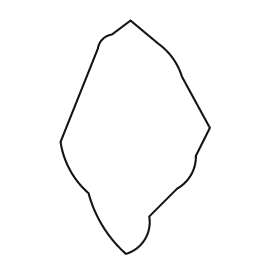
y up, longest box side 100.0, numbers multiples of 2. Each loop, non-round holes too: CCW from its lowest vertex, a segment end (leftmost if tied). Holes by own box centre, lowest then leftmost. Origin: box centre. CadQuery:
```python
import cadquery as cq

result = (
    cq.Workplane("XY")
    .moveTo(-4.0, -50.0)
    .threePointArc((4.0, -44.0), (6.0, -34.0))
    .lineTo(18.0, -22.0)
    .threePointArc((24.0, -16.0), (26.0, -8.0))
    .lineTo(32.0, 4.0)
    .lineTo(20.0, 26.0)
    .threePointArc((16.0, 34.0), (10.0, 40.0))
    .lineTo(-2.0, 50.0)
    .lineTo(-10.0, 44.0)
    .threePointArc((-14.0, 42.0), (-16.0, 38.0))
    .lineTo(-32.0, -2.0)
    .threePointArc((-28.0, -14.0), (-20.0, -24.0))
    .threePointArc((-14.0, -38.0), (-4.0, -50.0))
    .close()
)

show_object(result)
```